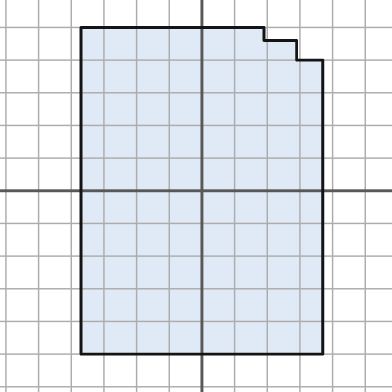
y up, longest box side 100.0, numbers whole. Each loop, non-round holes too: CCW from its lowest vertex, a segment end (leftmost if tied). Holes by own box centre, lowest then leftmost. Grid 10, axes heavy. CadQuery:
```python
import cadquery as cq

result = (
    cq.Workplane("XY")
    .moveTo(-37.0, -50.0)
    .lineTo(37.0, -50.0)
    .lineTo(37.0, 40.0)
    .lineTo(29.0, 40.0)
    .lineTo(29.0, 46.0)
    .lineTo(19.0, 46.0)
    .lineTo(19.0, 50.0)
    .lineTo(-37.0, 50.0)
    .close()
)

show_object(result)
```